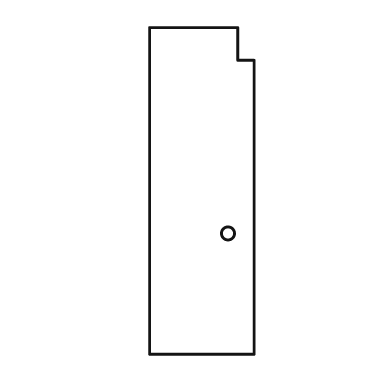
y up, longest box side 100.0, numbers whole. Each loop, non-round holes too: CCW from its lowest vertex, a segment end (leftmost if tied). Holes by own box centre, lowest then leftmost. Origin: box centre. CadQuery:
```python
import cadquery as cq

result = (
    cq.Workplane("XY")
    .moveTo(-16.0, -50.0)
    .lineTo(16.0, -50.0)
    .lineTo(16.0, 40.0)
    .lineTo(11.0, 40.0)
    .lineTo(11.0, 50.0)
    .lineTo(-16.0, 50.0)
    .close()
    .moveTo(8.0, -13.0)
    .circle(2.0)
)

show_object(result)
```